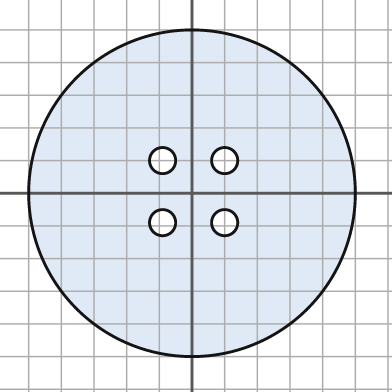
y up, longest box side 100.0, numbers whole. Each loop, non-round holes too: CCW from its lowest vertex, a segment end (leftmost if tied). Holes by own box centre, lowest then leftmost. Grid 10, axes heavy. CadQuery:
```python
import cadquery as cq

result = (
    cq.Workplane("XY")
    .moveTo(0.0, 0.0)
    .circle(50.0)
    .moveTo(-9.0, -9.0)
    .circle(4.0)
    .moveTo(10.0, -9.0)
    .circle(4.0)
    .moveTo(-9.0, 10.0)
    .circle(4.0)
    .moveTo(10.0, 10.0)
    .circle(4.0)
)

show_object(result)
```